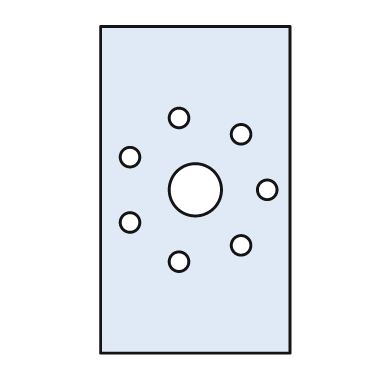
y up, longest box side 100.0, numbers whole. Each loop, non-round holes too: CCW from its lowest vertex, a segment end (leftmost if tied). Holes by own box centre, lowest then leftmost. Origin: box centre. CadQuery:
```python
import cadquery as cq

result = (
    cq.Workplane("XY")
    .moveTo(-29.0, -50.0)
    .lineTo(29.0, -50.0)
    .lineTo(29.0, 50.0)
    .lineTo(-29.0, 50.0)
    .close()
    .moveTo(-5.0, -22.0)
    .circle(3.0)
    .moveTo(14.0, -17.0)
    .circle(3.0)
    .moveTo(-20.0, -10.0)
    .circle(3.0)
    .moveTo(0.0, 0.0)
    .circle(8.0)
    .moveTo(22.0, 0.0)
    .circle(3.0)
    .moveTo(-20.0, 10.0)
    .circle(3.0)
    .moveTo(14.0, 17.0)
    .circle(3.0)
    .moveTo(-5.0, 22.0)
    .circle(3.0)
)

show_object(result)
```